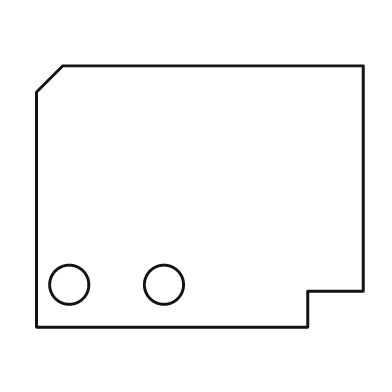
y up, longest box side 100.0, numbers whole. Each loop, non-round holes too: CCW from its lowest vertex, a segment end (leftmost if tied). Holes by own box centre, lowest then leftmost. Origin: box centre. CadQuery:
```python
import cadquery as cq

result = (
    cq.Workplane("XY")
    .moveTo(-50.0, -40.0)
    .lineTo(33.0, -40.0)
    .lineTo(33.0, -29.0)
    .lineTo(50.0, -29.0)
    .lineTo(50.0, 40.0)
    .lineTo(-42.0, 40.0)
    .lineTo(-50.0, 32.0)
    .close()
    .moveTo(-40.0, -27.0)
    .circle(6.0)
    .moveTo(-11.0, -27.0)
    .circle(6.0)
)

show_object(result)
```